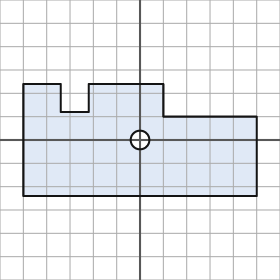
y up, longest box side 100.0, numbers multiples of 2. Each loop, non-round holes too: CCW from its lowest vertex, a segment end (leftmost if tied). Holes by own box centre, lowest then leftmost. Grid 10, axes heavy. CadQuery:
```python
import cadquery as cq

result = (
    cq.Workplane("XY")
    .moveTo(-50.0, -24.0)
    .lineTo(50.0, -24.0)
    .lineTo(50.0, 10.0)
    .lineTo(10.0, 10.0)
    .lineTo(10.0, 24.0)
    .lineTo(-22.0, 24.0)
    .lineTo(-22.0, 12.0)
    .lineTo(-34.0, 12.0)
    .lineTo(-34.0, 24.0)
    .lineTo(-50.0, 24.0)
    .close()
    .moveTo(0.0, 0.0)
    .circle(4.0)
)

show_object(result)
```